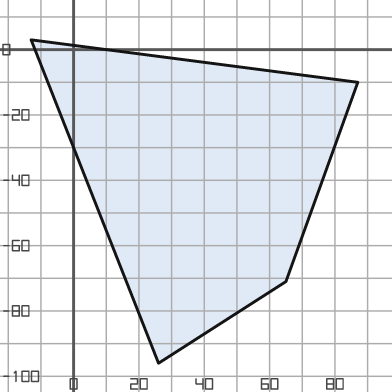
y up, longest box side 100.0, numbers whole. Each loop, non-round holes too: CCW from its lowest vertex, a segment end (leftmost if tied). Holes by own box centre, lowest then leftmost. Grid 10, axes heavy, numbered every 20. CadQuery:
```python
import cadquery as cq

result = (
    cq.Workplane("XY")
    .moveTo(26.0, -96.0)
    .lineTo(65.0, -71.0)
    .lineTo(87.0, -10.0)
    .lineTo(-13.0, 3.0)
    .close()
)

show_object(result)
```